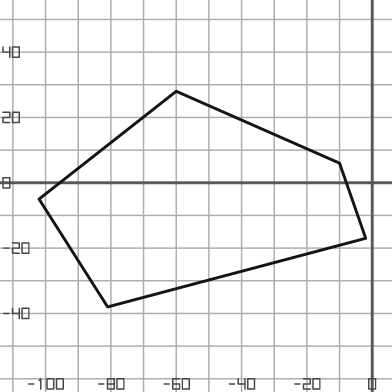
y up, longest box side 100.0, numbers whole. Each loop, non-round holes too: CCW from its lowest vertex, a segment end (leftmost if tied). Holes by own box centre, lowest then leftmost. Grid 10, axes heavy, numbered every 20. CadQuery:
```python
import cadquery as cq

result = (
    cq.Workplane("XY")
    .moveTo(-81.0, -38.0)
    .lineTo(-2.0, -17.0)
    .lineTo(-10.0, 6.0)
    .lineTo(-60.0, 28.0)
    .lineTo(-102.0, -5.0)
    .close()
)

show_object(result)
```